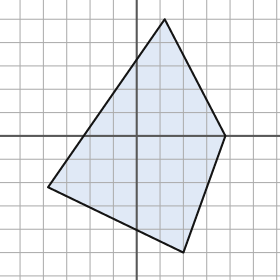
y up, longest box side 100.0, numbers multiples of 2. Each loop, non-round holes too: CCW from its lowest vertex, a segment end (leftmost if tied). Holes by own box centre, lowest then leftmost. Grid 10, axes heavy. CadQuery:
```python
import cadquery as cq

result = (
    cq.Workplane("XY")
    .moveTo(20.0, -50.0)
    .lineTo(38.0, 0.0)
    .lineTo(12.0, 50.0)
    .lineTo(-38.0, -22.0)
    .close()
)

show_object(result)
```